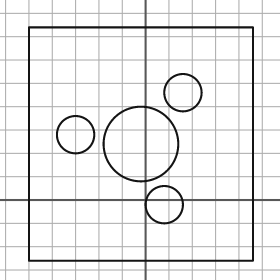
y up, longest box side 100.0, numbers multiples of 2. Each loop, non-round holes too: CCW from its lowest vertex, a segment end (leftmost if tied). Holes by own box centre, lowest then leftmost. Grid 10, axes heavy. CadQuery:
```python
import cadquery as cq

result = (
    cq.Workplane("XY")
    .moveTo(-50.0, -26.0)
    .lineTo(46.0, -26.0)
    .lineTo(46.0, 74.0)
    .lineTo(-50.0, 74.0)
    .close()
    .moveTo(8.0, -2.0)
    .circle(8.0)
    .moveTo(-2.0, 24.0)
    .circle(16.0)
    .moveTo(-30.0, 28.0)
    .circle(8.0)
    .moveTo(16.0, 46.0)
    .circle(8.0)
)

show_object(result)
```